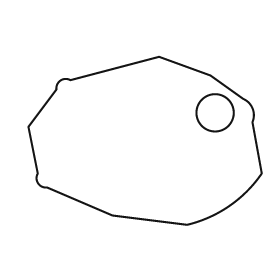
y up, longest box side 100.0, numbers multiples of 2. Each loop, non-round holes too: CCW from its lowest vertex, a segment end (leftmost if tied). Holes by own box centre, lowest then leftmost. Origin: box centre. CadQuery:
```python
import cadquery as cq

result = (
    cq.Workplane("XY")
    .moveTo(18.0, -36.0)
    .threePointArc((36.0, -28.0), (50.0, -14.0))
    .lineTo(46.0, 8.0)
    .threePointArc((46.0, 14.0), (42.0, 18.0))
    .lineTo(28.0, 28.0)
    .lineTo(6.0, 36.0)
    .lineTo(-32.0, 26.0)
    .threePointArc((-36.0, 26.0), (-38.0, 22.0))
    .lineTo(-50.0, 6.0)
    .lineTo(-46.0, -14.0)
    .threePointArc((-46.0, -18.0), (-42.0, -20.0))
    .lineTo(-14.0, -32.0)
    .close()
    .moveTo(30.0, 12.0)
    .circle(8.0)
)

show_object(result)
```